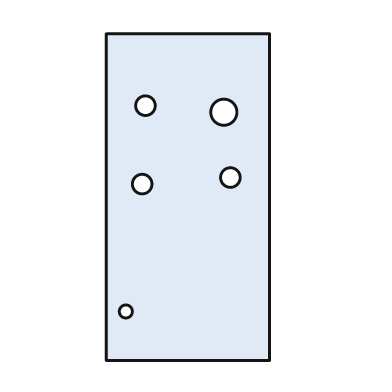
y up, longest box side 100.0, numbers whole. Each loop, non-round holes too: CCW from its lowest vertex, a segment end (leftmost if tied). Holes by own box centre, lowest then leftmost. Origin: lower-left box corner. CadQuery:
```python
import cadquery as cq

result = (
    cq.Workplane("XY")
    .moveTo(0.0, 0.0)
    .lineTo(50.0, 0.0)
    .lineTo(50.0, 100.0)
    .lineTo(0.0, 100.0)
    .close()
    .moveTo(6.0, 15.0)
    .circle(2.0)
    .moveTo(11.0, 54.0)
    .circle(3.0)
    .moveTo(38.0, 56.0)
    .circle(3.0)
    .moveTo(36.0, 76.0)
    .circle(4.0)
    .moveTo(12.0, 78.0)
    .circle(3.0)
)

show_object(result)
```